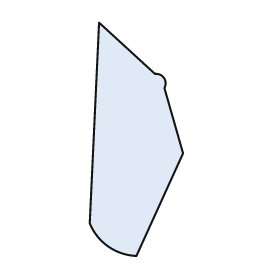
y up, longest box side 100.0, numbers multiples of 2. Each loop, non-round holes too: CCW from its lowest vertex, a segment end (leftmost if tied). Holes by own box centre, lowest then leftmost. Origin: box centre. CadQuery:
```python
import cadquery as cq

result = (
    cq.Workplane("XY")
    .moveTo(0.0, -50.0)
    .lineTo(20.0, -6.0)
    .lineTo(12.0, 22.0)
    .threePointArc((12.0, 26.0), (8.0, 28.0))
    .lineTo(-16.0, 50.0)
    .lineTo(-20.0, -36.0)
    .threePointArc((-12.0, -46.0), (0.0, -50.0))
    .close()
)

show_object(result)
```